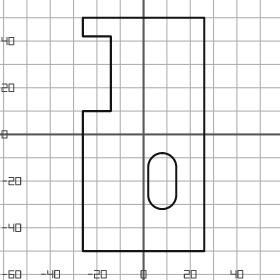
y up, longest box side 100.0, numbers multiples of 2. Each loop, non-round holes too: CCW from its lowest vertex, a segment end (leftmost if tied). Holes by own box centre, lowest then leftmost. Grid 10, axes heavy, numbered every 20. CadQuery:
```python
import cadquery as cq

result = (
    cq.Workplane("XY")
    .moveTo(-26.0, -50.0)
    .lineTo(26.0, -50.0)
    .lineTo(26.0, 50.0)
    .lineTo(-26.0, 50.0)
    .lineTo(-26.0, 42.0)
    .lineTo(-14.0, 42.0)
    .lineTo(-14.0, 10.0)
    .lineTo(-26.0, 10.0)
    .close()
    .moveTo(2.0, -26.0)
    .threePointArc((8.0, -32.0), (14.0, -26.0))
    .lineTo(14.0, -14.0)
    .threePointArc((8.0, -8.0), (2.0, -14.0))
    .close()
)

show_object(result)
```